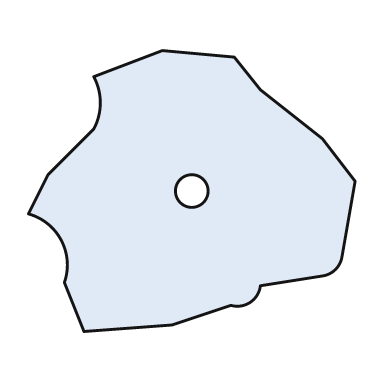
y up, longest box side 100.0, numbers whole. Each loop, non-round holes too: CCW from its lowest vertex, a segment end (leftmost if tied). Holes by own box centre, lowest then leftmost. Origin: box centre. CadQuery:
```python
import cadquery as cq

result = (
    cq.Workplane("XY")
    .moveTo(-33.0, -43.0)
    .lineTo(-6.0, -41.0)
    .lineTo(12.0, -35.0)
    .threePointArc((18.0, -34.0), (21.0, -29.0))
    .lineTo(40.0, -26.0)
    .threePointArc((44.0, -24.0), (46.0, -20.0))
    .lineTo(50.0, 3.0)
    .lineTo(40.0, 16.0)
    .lineTo(21.0, 31.0)
    .lineTo(13.0, 41.0)
    .lineTo(-9.0, 43.0)
    .lineTo(-30.0, 35.0)
    .threePointArc((-28.0, 27.0), (-30.0, 19.0))
    .lineTo(-44.0, 5.0)
    .lineTo(-50.0, -7.0)
    .threePointArc((-40.0, -15.0), (-39.0, -28.0))
    .close()
    .moveTo(0.0, 0.0)
    .circle(5.0)
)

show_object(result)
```